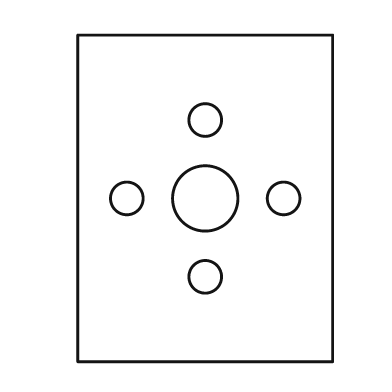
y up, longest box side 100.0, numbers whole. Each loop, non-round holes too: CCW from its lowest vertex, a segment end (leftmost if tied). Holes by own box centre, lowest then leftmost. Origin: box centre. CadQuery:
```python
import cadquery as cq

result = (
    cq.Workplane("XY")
    .moveTo(-39.0, -50.0)
    .lineTo(39.0, -50.0)
    .lineTo(39.0, 50.0)
    .lineTo(-39.0, 50.0)
    .close()
    .moveTo(0.0, -24.0)
    .circle(5.0)
    .moveTo(-24.0, 0.0)
    .circle(5.0)
    .moveTo(0.0, 0.0)
    .circle(10.0)
    .moveTo(24.0, 0.0)
    .circle(5.0)
    .moveTo(0.0, 24.0)
    .circle(5.0)
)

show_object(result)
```